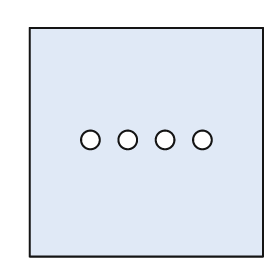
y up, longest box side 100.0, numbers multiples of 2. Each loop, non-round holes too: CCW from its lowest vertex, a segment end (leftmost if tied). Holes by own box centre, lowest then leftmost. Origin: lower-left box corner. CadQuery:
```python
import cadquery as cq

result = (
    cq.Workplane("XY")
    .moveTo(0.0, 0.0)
    .lineTo(100.0, 0.0)
    .lineTo(100.0, 98.0)
    .lineTo(0.0, 98.0)
    .close()
    .moveTo(26.0, 50.0)
    .circle(4.0)
    .moveTo(42.0, 50.0)
    .circle(4.0)
    .moveTo(58.0, 50.0)
    .circle(4.0)
    .moveTo(74.0, 50.0)
    .circle(4.0)
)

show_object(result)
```